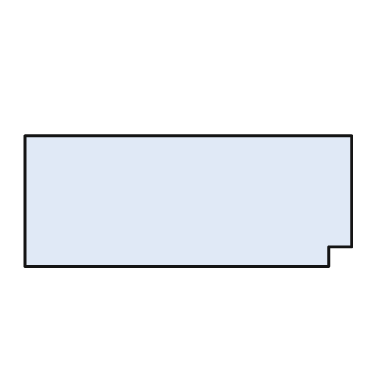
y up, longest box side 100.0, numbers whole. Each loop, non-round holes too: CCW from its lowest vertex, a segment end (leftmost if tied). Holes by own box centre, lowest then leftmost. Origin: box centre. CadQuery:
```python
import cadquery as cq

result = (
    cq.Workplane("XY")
    .moveTo(-50.0, -20.0)
    .lineTo(43.0, -20.0)
    .lineTo(43.0, -14.0)
    .lineTo(50.0, -14.0)
    .lineTo(50.0, 20.0)
    .lineTo(-50.0, 20.0)
    .close()
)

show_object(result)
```